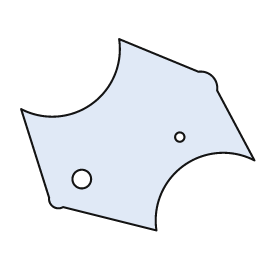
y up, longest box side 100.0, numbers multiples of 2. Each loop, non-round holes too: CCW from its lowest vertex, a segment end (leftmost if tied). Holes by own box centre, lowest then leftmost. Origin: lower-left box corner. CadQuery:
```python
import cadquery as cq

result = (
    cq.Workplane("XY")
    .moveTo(58.0, 0.0)
    .threePointArc((70.0, 28.0), (100.0, 30.0))
    .lineTo(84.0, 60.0)
    .threePointArc((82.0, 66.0), (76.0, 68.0))
    .lineTo(42.0, 82.0)
    .threePointArc((30.0, 54.0), (0.0, 52.0))
    .lineTo(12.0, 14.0)
    .threePointArc((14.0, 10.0), (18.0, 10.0))
    .close()
    .moveTo(26.0, 22.0)
    .circle(4.0)
    .moveTo(68.0, 40.0)
    .circle(2.0)
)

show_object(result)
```